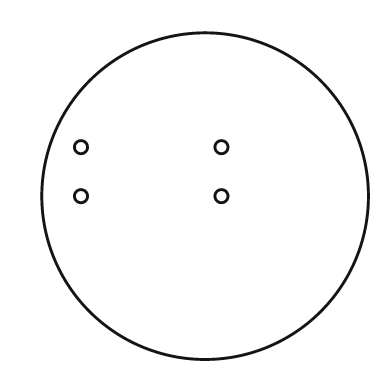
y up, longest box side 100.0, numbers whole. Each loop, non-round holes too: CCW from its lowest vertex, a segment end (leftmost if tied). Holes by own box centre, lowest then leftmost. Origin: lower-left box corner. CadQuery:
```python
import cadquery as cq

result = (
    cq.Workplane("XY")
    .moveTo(50.0, 50.0)
    .circle(50.0)
    .moveTo(12.0, 50.0)
    .circle(2.0)
    .moveTo(55.0, 50.0)
    .circle(2.0)
    .moveTo(12.0, 65.0)
    .circle(2.0)
    .moveTo(55.0, 65.0)
    .circle(2.0)
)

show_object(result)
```